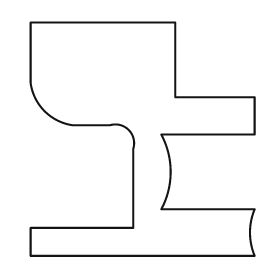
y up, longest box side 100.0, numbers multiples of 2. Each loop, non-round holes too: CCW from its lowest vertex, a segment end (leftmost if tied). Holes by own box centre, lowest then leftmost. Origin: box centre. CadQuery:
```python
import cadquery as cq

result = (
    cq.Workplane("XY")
    .moveTo(-48.0, -50.0)
    .lineTo(48.0, -50.0)
    .threePointArc((46.0, -40.0), (48.0, -30.0))
    .lineTo(8.0, -30.0)
    .threePointArc((12.0, -14.0), (8.0, 2.0))
    .lineTo(48.0, 2.0)
    .lineTo(48.0, 18.0)
    .lineTo(14.0, 18.0)
    .lineTo(14.0, 50.0)
    .lineTo(-48.0, 50.0)
    .lineTo(-48.0, 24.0)
    .threePointArc((-42.0, 12.0), (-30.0, 6.0))
    .lineTo(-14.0, 6.0)
    .threePointArc((-6.0, 4.0), (-4.0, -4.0))
    .lineTo(-4.0, -38.0)
    .lineTo(-48.0, -38.0)
    .close()
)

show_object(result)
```